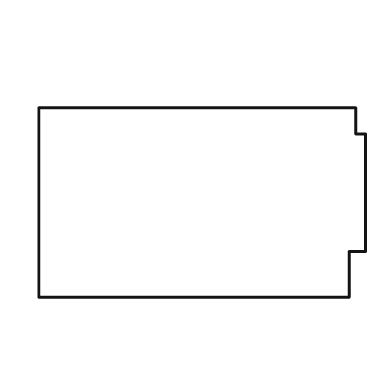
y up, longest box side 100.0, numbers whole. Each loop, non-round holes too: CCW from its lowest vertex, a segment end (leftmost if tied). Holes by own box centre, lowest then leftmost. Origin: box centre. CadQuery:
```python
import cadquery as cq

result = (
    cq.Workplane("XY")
    .moveTo(-50.0, -29.0)
    .lineTo(45.0, -29.0)
    .lineTo(45.0, -15.0)
    .lineTo(50.0, -15.0)
    .lineTo(50.0, 21.0)
    .lineTo(47.0, 21.0)
    .lineTo(47.0, 29.0)
    .lineTo(-50.0, 29.0)
    .close()
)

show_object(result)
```